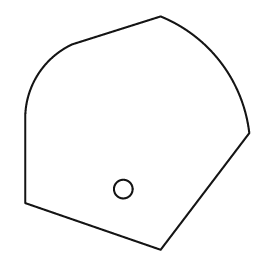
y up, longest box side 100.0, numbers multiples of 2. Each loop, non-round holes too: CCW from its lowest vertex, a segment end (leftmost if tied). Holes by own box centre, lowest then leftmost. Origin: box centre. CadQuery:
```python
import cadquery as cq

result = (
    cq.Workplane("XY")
    .moveTo(10.0, -50.0)
    .lineTo(48.0, 0.0)
    .threePointArc((36.0, 30.0), (10.0, 50.0))
    .lineTo(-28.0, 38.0)
    .threePointArc((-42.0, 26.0), (-48.0, 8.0))
    .lineTo(-48.0, -30.0)
    .close()
    .moveTo(-6.0, -24.0)
    .circle(4.0)
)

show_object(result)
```